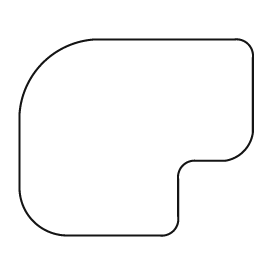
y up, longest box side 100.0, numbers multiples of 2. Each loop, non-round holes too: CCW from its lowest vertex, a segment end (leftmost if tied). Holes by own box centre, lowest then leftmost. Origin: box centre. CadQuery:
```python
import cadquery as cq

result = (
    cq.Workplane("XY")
    .moveTo(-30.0, -42.0)
    .lineTo(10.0, -42.0)
    .threePointArc((16.0, -40.0), (18.0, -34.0))
    .lineTo(18.0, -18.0)
    .threePointArc((20.0, -12.0), (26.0, -10.0))
    .lineTo(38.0, -10.0)
    .threePointArc((46.0, -6.0), (50.0, 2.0))
    .lineTo(50.0, 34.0)
    .threePointArc((48.0, 40.0), (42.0, 42.0))
    .lineTo(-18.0, 42.0)
    .threePointArc((-40.0, 32.0), (-50.0, 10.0))
    .lineTo(-50.0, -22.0)
    .threePointArc((-44.0, -36.0), (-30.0, -42.0))
    .close()
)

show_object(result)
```